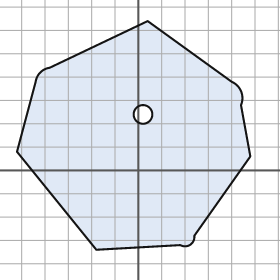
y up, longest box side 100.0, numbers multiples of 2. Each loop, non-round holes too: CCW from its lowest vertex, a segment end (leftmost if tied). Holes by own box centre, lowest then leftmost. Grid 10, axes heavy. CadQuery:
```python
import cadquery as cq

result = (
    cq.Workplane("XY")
    .moveTo(-18.0, -34.0)
    .lineTo(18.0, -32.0)
    .threePointArc((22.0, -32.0), (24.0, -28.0))
    .lineTo(48.0, 6.0)
    .lineTo(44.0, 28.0)
    .threePointArc((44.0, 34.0), (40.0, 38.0))
    .lineTo(4.0, 64.0)
    .lineTo(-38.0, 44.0)
    .threePointArc((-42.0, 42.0), (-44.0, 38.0))
    .lineTo(-52.0, 8.0)
    .close()
    .moveTo(2.0, 24.0)
    .circle(4.0)
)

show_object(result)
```